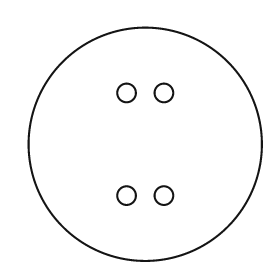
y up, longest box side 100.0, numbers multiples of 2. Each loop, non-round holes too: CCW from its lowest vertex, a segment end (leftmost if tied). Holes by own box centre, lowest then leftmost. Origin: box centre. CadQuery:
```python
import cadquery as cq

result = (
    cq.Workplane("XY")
    .moveTo(0.0, 0.0)
    .circle(50.0)
    .moveTo(-8.0, -22.0)
    .circle(4.0)
    .moveTo(8.0, -22.0)
    .circle(4.0)
    .moveTo(-8.0, 22.0)
    .circle(4.0)
    .moveTo(8.0, 22.0)
    .circle(4.0)
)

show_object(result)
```